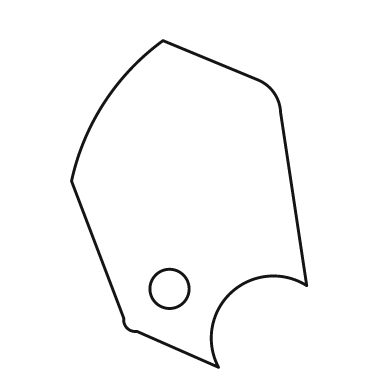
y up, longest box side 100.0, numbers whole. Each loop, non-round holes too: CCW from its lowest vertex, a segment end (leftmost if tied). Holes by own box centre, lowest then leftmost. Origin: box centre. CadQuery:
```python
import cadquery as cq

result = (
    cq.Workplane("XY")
    .moveTo(9.0, -50.0)
    .threePointArc((13.0, -27.0), (36.0, -25.0))
    .lineTo(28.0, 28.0)
    .threePointArc((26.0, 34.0), (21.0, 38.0))
    .lineTo(-8.0, 50.0)
    .threePointArc((-26.0, 31.0), (-36.0, 7.0))
    .lineTo(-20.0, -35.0)
    .threePointArc((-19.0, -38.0), (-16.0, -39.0))
    .close()
    .moveTo(-6.0, -26.0)
    .circle(6.0)
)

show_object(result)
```